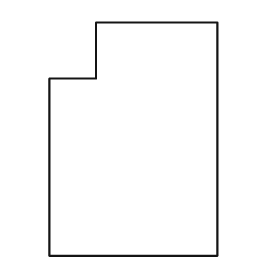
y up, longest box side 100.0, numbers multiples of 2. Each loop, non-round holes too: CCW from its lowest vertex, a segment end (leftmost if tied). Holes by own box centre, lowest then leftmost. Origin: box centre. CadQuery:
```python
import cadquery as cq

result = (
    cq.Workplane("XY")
    .moveTo(-36.0, -50.0)
    .lineTo(36.0, -50.0)
    .lineTo(36.0, 50.0)
    .lineTo(-16.0, 50.0)
    .lineTo(-16.0, 26.0)
    .lineTo(-36.0, 26.0)
    .close()
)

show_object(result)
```